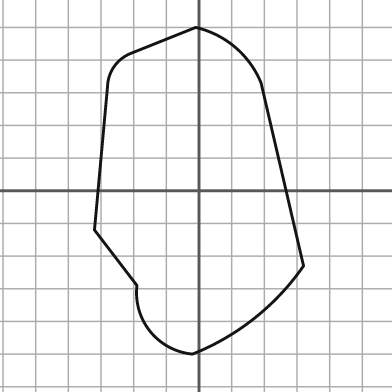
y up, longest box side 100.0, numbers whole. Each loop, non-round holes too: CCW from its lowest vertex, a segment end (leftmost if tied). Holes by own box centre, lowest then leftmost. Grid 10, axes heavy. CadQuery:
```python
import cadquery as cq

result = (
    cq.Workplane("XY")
    .moveTo(-2.0, -50.0)
    .threePointArc((17.0, -39.0), (32.0, -23.0))
    .lineTo(19.0, 33.0)
    .threePointArc((11.0, 44.0), (-1.0, 50.0))
    .lineTo(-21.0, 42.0)
    .threePointArc((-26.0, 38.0), (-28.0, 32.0))
    .lineTo(-32.0, -12.0)
    .lineTo(-19.0, -29.0)
    .threePointArc((-15.0, -43.0), (-2.0, -50.0))
    .close()
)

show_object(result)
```